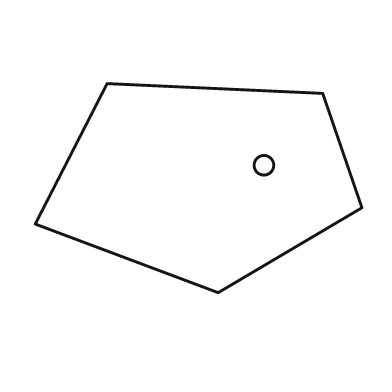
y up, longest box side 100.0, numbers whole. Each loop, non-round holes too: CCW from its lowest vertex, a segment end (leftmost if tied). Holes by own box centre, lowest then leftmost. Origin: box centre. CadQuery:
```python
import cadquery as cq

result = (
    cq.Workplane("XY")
    .moveTo(6.0, -32.0)
    .lineTo(50.0, -6.0)
    .lineTo(38.0, 29.0)
    .lineTo(-28.0, 32.0)
    .lineTo(-50.0, -11.0)
    .close()
    .moveTo(20.0, 7.0)
    .circle(3.0)
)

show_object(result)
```